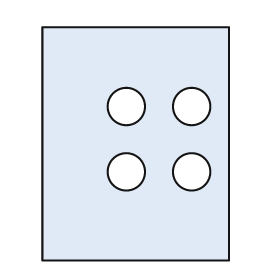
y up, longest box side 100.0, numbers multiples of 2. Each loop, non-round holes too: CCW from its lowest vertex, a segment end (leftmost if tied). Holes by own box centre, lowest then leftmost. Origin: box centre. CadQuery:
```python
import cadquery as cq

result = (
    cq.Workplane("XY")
    .moveTo(-40.0, -50.0)
    .lineTo(40.0, -50.0)
    .lineTo(40.0, 50.0)
    .lineTo(-40.0, 50.0)
    .close()
    .moveTo(-4.0, -12.0)
    .circle(8.0)
    .moveTo(24.0, -12.0)
    .circle(8.0)
    .moveTo(-4.0, 16.0)
    .circle(8.0)
    .moveTo(24.0, 16.0)
    .circle(8.0)
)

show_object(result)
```